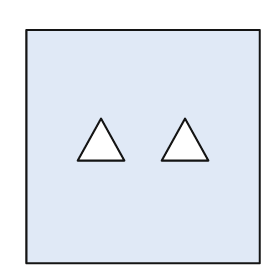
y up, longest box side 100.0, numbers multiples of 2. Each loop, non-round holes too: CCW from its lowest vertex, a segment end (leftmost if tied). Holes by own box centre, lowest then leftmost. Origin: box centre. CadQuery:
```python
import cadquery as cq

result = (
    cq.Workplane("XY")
    .moveTo(-50.0, -50.0)
    .lineTo(50.0, -50.0)
    .lineTo(50.0, 50.0)
    .lineTo(-50.0, 50.0)
    .close()
    .moveTo(-28.0, -6.0)
    .lineTo(-8.0, -6.0)
    .lineTo(-18.0, 12.0)
    .close()
    .moveTo(8.0, -6.0)
    .lineTo(28.0, -6.0)
    .lineTo(18.0, 12.0)
    .close()
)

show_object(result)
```